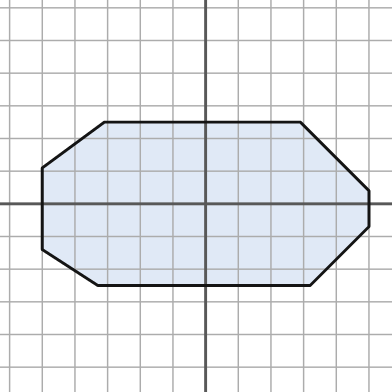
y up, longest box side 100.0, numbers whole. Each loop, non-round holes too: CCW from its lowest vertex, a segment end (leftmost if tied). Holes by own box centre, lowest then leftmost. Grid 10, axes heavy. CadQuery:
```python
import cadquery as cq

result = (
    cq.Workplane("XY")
    .moveTo(-33.0, -25.0)
    .lineTo(32.0, -25.0)
    .lineTo(50.0, -7.0)
    .lineTo(50.0, 4.0)
    .lineTo(29.0, 25.0)
    .lineTo(-31.0, 25.0)
    .lineTo(-50.0, 11.0)
    .lineTo(-50.0, -14.0)
    .close()
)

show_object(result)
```